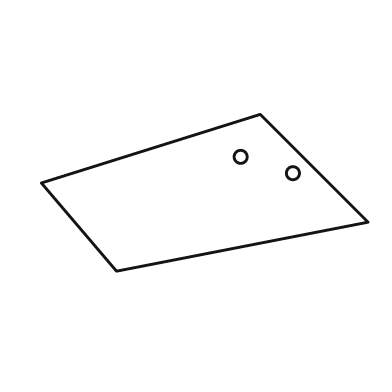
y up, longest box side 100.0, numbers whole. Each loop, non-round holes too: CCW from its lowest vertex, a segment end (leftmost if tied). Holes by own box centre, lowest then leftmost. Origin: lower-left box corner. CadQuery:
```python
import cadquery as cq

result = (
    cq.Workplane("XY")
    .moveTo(23.0, 0.0)
    .lineTo(100.0, 15.0)
    .lineTo(67.0, 48.0)
    .lineTo(0.0, 27.0)
    .close()
    .moveTo(77.0, 30.0)
    .circle(2.0)
    .moveTo(61.0, 35.0)
    .circle(2.0)
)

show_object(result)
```